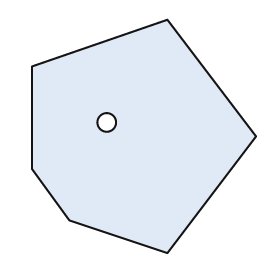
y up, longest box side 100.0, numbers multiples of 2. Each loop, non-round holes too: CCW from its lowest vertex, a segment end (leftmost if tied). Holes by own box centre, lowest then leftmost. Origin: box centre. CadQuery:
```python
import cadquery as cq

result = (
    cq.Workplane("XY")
    .moveTo(10.0, -50.0)
    .lineTo(48.0, 0.0)
    .lineTo(10.0, 50.0)
    .lineTo(-48.0, 30.0)
    .lineTo(-48.0, -14.0)
    .lineTo(-32.0, -36.0)
    .close()
    .moveTo(-16.0, 6.0)
    .circle(4.0)
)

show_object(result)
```